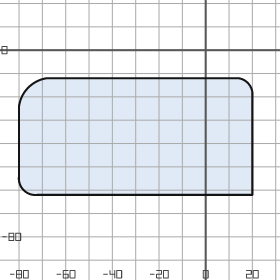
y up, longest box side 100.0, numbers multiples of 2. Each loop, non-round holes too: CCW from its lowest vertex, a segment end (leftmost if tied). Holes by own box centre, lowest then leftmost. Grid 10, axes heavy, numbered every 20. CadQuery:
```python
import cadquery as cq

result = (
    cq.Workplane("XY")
    .moveTo(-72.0, -62.0)
    .lineTo(20.0, -62.0)
    .lineTo(20.0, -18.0)
    .threePointArc((18.0, -14.0), (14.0, -12.0))
    .lineTo(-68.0, -12.0)
    .threePointArc((-76.0, -16.0), (-80.0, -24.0))
    .lineTo(-80.0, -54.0)
    .threePointArc((-78.0, -60.0), (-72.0, -62.0))
    .close()
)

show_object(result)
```